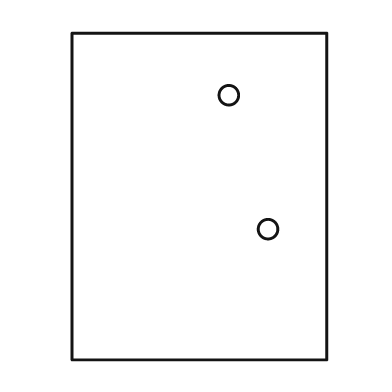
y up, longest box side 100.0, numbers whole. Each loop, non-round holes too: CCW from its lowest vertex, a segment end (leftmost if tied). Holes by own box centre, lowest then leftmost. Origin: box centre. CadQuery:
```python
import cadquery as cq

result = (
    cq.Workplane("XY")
    .moveTo(-39.0, -50.0)
    .lineTo(39.0, -50.0)
    .lineTo(39.0, 50.0)
    .lineTo(-39.0, 50.0)
    .close()
    .moveTo(21.0, -10.0)
    .circle(3.0)
    .moveTo(9.0, 31.0)
    .circle(3.0)
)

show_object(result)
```